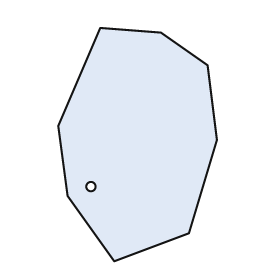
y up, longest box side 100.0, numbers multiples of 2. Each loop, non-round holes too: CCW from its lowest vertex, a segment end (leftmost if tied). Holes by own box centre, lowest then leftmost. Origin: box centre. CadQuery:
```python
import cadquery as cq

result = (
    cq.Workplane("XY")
    .moveTo(-10.0, -50.0)
    .lineTo(22.0, -38.0)
    .lineTo(34.0, 2.0)
    .lineTo(30.0, 34.0)
    .lineTo(10.0, 48.0)
    .lineTo(-16.0, 50.0)
    .lineTo(-34.0, 8.0)
    .lineTo(-30.0, -22.0)
    .close()
    .moveTo(-20.0, -18.0)
    .circle(2.0)
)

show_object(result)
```